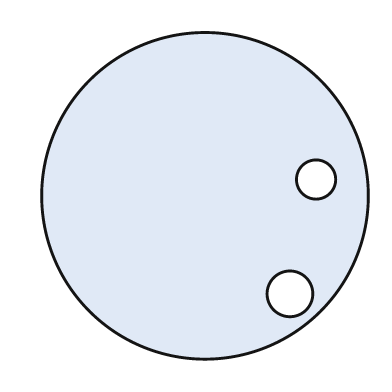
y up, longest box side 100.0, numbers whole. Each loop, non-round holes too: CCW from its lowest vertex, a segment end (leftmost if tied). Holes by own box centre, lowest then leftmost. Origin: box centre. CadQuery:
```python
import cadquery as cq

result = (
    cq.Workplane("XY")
    .moveTo(0.0, 0.0)
    .circle(50.0)
    .moveTo(26.0, -30.0)
    .circle(7.0)
    .moveTo(34.0, 5.0)
    .circle(6.0)
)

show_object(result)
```